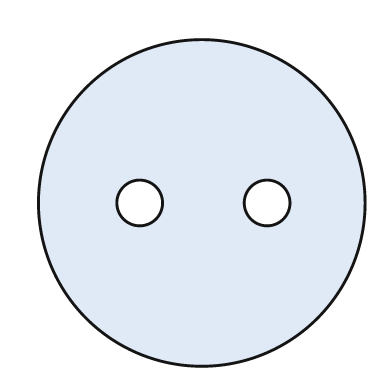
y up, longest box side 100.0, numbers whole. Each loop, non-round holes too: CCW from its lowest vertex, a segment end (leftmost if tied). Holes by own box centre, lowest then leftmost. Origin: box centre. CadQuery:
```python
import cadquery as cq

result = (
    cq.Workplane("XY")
    .moveTo(0.0, 0.0)
    .circle(50.0)
    .moveTo(-19.0, 0.0)
    .circle(7.0)
    .moveTo(20.0, 0.0)
    .circle(7.0)
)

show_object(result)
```